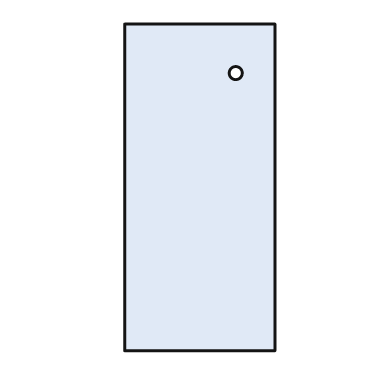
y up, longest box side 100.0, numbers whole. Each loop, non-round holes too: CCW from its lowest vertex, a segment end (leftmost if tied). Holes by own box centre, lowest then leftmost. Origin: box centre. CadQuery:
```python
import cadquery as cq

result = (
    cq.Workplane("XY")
    .moveTo(-23.0, -50.0)
    .lineTo(23.0, -50.0)
    .lineTo(23.0, 50.0)
    .lineTo(-23.0, 50.0)
    .close()
    .moveTo(11.0, 35.0)
    .circle(2.0)
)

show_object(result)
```